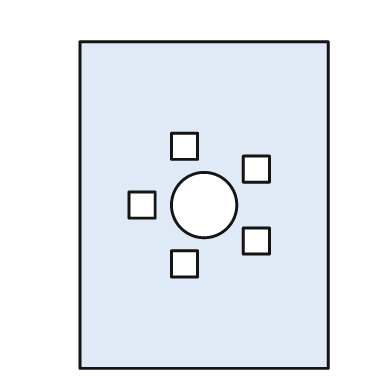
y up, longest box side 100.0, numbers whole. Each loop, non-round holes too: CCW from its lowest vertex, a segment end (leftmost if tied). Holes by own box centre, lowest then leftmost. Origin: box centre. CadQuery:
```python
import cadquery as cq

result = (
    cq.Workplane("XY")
    .moveTo(-38.0, -50.0)
    .lineTo(38.0, -50.0)
    .lineTo(38.0, 50.0)
    .lineTo(-38.0, 50.0)
    .close()
    .moveTo(-10.0, -22.0)
    .lineTo(-2.0, -22.0)
    .lineTo(-2.0, -14.0)
    .lineTo(-10.0, -14.0)
    .close()
    .moveTo(12.0, -15.0)
    .lineTo(20.0, -15.0)
    .lineTo(20.0, -7.0)
    .lineTo(12.0, -7.0)
    .close()
    .moveTo(-23.0, -4.0)
    .lineTo(-15.0, -4.0)
    .lineTo(-15.0, 4.0)
    .lineTo(-23.0, 4.0)
    .close()
    .moveTo(0.0, 0.0)
    .circle(10.0)
    .moveTo(12.0, 7.0)
    .lineTo(20.0, 7.0)
    .lineTo(20.0, 15.0)
    .lineTo(12.0, 15.0)
    .close()
    .moveTo(-10.0, 14.0)
    .lineTo(-2.0, 14.0)
    .lineTo(-2.0, 22.0)
    .lineTo(-10.0, 22.0)
    .close()
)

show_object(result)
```